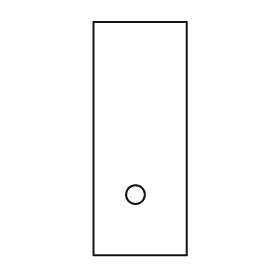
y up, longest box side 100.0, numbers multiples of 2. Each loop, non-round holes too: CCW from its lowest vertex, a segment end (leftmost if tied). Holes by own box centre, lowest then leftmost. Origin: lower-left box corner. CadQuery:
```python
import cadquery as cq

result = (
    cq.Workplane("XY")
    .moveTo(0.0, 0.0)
    .lineTo(40.0, 0.0)
    .lineTo(40.0, 100.0)
    .lineTo(0.0, 100.0)
    .close()
    .moveTo(18.0, 26.0)
    .circle(4.0)
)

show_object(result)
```